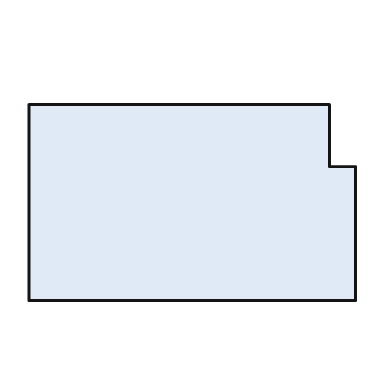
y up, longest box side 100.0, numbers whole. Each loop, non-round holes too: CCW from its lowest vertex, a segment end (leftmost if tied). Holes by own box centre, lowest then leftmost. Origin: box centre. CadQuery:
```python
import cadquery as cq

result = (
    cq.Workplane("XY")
    .moveTo(-50.0, -30.0)
    .lineTo(50.0, -30.0)
    .lineTo(50.0, 11.0)
    .lineTo(42.0, 11.0)
    .lineTo(42.0, 30.0)
    .lineTo(-50.0, 30.0)
    .close()
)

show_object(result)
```